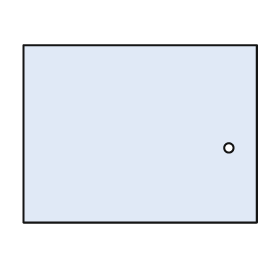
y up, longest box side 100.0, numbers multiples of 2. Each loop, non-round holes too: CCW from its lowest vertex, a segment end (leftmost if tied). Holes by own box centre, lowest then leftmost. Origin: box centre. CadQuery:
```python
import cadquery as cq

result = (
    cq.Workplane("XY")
    .moveTo(-50.0, -38.0)
    .lineTo(50.0, -38.0)
    .lineTo(50.0, 38.0)
    .lineTo(-50.0, 38.0)
    .close()
    .moveTo(38.0, -6.0)
    .circle(2.0)
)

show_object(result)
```